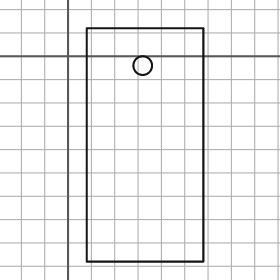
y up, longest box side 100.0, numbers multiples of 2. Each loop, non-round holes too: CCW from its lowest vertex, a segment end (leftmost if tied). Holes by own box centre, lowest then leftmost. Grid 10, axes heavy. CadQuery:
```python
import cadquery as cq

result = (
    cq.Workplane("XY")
    .moveTo(8.0, -88.0)
    .lineTo(58.0, -88.0)
    .lineTo(58.0, 12.0)
    .lineTo(8.0, 12.0)
    .close()
    .moveTo(32.0, -4.0)
    .circle(4.0)
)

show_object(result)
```